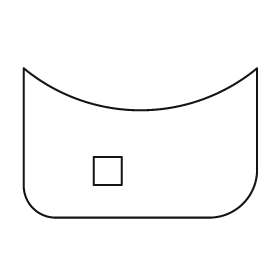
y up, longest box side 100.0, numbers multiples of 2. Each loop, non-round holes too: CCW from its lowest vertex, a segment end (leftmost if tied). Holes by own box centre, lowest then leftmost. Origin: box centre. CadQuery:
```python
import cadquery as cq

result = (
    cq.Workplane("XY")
    .moveTo(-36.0, -32.0)
    .lineTo(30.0, -32.0)
    .threePointArc((44.0, -26.0), (50.0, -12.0))
    .lineTo(50.0, 32.0)
    .threePointArc((0.0, 14.0), (-50.0, 32.0))
    .lineTo(-50.0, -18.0)
    .threePointArc((-46.0, -28.0), (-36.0, -32.0))
    .close()
    .moveTo(-20.0, -18.0)
    .lineTo(-8.0, -18.0)
    .lineTo(-8.0, -6.0)
    .lineTo(-20.0, -6.0)
    .close()
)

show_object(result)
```